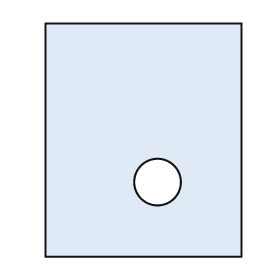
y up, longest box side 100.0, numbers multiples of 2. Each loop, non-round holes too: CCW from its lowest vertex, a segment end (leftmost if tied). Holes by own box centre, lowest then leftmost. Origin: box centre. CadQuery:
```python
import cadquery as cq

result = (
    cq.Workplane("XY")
    .moveTo(-42.0, -50.0)
    .lineTo(42.0, -50.0)
    .lineTo(42.0, 50.0)
    .lineTo(-42.0, 50.0)
    .close()
    .moveTo(6.0, -18.0)
    .circle(10.0)
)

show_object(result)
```